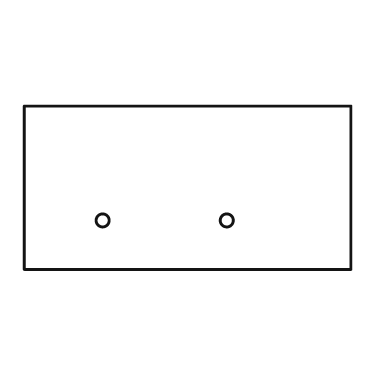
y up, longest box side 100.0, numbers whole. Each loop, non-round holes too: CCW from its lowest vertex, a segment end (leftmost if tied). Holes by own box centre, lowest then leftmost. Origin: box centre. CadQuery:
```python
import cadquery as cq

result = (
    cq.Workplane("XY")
    .moveTo(-50.0, -25.0)
    .lineTo(50.0, -25.0)
    .lineTo(50.0, 25.0)
    .lineTo(-50.0, 25.0)
    .close()
    .moveTo(-26.0, -10.0)
    .circle(2.0)
    .moveTo(12.0, -10.0)
    .circle(2.0)
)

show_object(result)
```